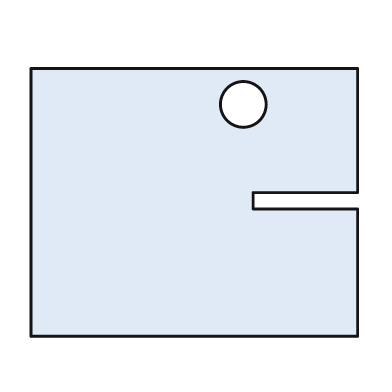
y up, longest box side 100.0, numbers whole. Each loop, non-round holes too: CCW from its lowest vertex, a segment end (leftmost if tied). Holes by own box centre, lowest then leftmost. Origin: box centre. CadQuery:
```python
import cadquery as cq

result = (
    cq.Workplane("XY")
    .moveTo(-50.0, -41.0)
    .lineTo(50.0, -41.0)
    .lineTo(50.0, -2.0)
    .lineTo(18.0, -2.0)
    .lineTo(18.0, 3.0)
    .lineTo(50.0, 3.0)
    .lineTo(50.0, 41.0)
    .lineTo(-50.0, 41.0)
    .close()
    .moveTo(15.0, 30.0)
    .circle(7.0)
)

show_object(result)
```